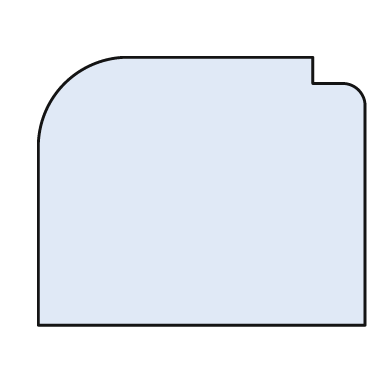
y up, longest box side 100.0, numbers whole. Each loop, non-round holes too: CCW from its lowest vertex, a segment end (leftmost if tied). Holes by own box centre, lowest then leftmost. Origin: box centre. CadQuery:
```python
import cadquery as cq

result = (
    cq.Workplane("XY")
    .moveTo(-50.0, -41.0)
    .lineTo(50.0, -41.0)
    .lineTo(50.0, 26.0)
    .threePointArc((48.0, 31.0), (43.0, 33.0))
    .lineTo(34.0, 33.0)
    .lineTo(34.0, 41.0)
    .lineTo(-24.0, 41.0)
    .threePointArc((-42.0, 33.0), (-50.0, 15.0))
    .close()
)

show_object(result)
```